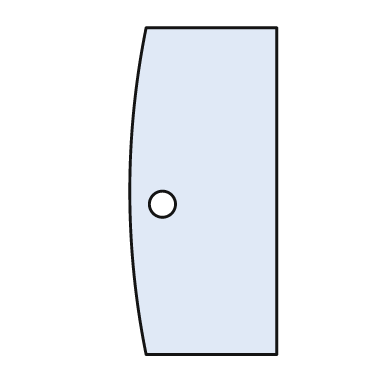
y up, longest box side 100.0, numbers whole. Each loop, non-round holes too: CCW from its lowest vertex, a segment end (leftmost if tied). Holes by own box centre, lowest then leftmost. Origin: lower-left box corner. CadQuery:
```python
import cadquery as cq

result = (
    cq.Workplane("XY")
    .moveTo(5.0, 0.0)
    .lineTo(45.0, 0.0)
    .lineTo(45.0, 100.0)
    .lineTo(5.0, 100.0)
    .threePointArc((0.0, 50.0), (5.0, 0.0))
    .close()
    .moveTo(10.0, 46.0)
    .circle(4.0)
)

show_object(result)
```